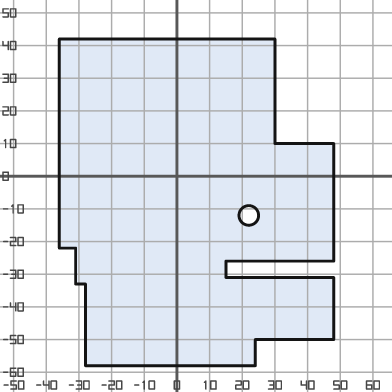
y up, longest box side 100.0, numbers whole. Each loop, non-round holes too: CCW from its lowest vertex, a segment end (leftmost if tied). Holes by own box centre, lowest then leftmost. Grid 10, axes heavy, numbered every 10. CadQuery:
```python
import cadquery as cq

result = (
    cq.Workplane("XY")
    .moveTo(-28.0, -58.0)
    .lineTo(24.0, -58.0)
    .lineTo(24.0, -50.0)
    .lineTo(48.0, -50.0)
    .lineTo(48.0, -31.0)
    .lineTo(15.0, -31.0)
    .lineTo(15.0, -26.0)
    .lineTo(48.0, -26.0)
    .lineTo(48.0, 10.0)
    .lineTo(30.0, 10.0)
    .lineTo(30.0, 42.0)
    .lineTo(-36.0, 42.0)
    .lineTo(-36.0, -22.0)
    .lineTo(-31.0, -22.0)
    .lineTo(-31.0, -33.0)
    .lineTo(-28.0, -33.0)
    .close()
    .moveTo(22.0, -12.0)
    .circle(3.0)
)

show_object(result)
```